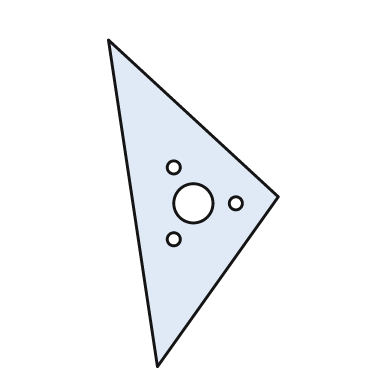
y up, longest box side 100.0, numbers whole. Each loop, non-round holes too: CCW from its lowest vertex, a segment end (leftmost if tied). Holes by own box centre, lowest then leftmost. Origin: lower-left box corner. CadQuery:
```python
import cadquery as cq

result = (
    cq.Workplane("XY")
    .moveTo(15.0, 0.0)
    .lineTo(52.0, 52.0)
    .lineTo(0.0, 100.0)
    .close()
    .moveTo(20.0, 39.0)
    .circle(2.0)
    .moveTo(26.0, 50.0)
    .circle(6.0)
    .moveTo(39.0, 50.0)
    .circle(2.0)
    .moveTo(20.0, 61.0)
    .circle(2.0)
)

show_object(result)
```